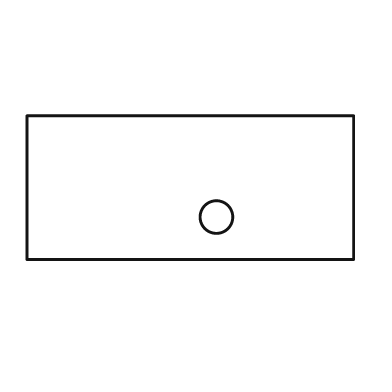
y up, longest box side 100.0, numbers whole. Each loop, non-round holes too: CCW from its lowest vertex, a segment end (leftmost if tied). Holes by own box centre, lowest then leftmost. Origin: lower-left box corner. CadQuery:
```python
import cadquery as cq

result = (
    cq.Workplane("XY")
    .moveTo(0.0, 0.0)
    .lineTo(100.0, 0.0)
    .lineTo(100.0, 44.0)
    .lineTo(0.0, 44.0)
    .close()
    .moveTo(58.0, 13.0)
    .circle(5.0)
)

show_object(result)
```